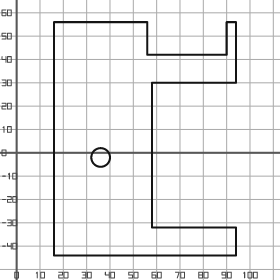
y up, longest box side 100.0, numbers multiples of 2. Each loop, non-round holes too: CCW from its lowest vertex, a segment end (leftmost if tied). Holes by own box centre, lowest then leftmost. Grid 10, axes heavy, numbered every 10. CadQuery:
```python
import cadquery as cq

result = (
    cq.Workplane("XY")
    .moveTo(16.0, -44.0)
    .lineTo(94.0, -44.0)
    .lineTo(94.0, -32.0)
    .lineTo(58.0, -32.0)
    .lineTo(58.0, 30.0)
    .lineTo(94.0, 30.0)
    .lineTo(94.0, 56.0)
    .lineTo(90.0, 56.0)
    .lineTo(90.0, 42.0)
    .lineTo(56.0, 42.0)
    .lineTo(56.0, 56.0)
    .lineTo(16.0, 56.0)
    .close()
    .moveTo(36.0, -2.0)
    .circle(4.0)
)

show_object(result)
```